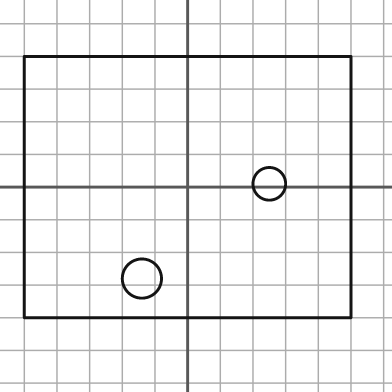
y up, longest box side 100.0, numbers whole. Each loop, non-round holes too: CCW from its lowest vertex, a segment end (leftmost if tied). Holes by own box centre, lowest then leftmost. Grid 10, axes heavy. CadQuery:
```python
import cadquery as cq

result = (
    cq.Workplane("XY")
    .moveTo(-50.0, -40.0)
    .lineTo(50.0, -40.0)
    .lineTo(50.0, 40.0)
    .lineTo(-50.0, 40.0)
    .close()
    .moveTo(-14.0, -28.0)
    .circle(6.0)
    .moveTo(25.0, 1.0)
    .circle(5.0)
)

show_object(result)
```